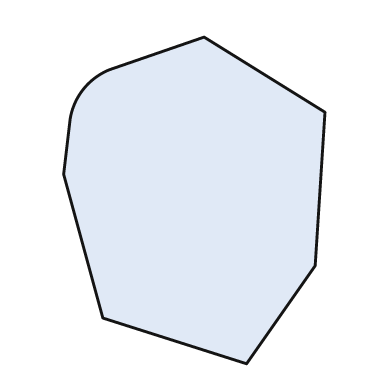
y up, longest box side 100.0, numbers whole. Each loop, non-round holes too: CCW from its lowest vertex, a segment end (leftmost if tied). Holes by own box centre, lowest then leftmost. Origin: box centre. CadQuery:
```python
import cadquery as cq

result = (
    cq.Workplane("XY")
    .moveTo(16.0, -50.0)
    .lineTo(37.0, -20.0)
    .lineTo(40.0, 27.0)
    .lineTo(3.0, 50.0)
    .lineTo(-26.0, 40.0)
    .threePointArc((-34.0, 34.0), (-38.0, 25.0))
    .lineTo(-40.0, 8.0)
    .lineTo(-28.0, -36.0)
    .close()
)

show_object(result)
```